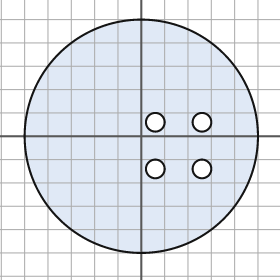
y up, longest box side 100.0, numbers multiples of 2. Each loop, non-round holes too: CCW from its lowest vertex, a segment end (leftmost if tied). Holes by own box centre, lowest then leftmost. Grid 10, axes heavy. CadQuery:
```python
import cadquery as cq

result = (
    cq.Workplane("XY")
    .moveTo(0.0, 0.0)
    .circle(50.0)
    .moveTo(6.0, -14.0)
    .circle(4.0)
    .moveTo(26.0, -14.0)
    .circle(4.0)
    .moveTo(6.0, 6.0)
    .circle(4.0)
    .moveTo(26.0, 6.0)
    .circle(4.0)
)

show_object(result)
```